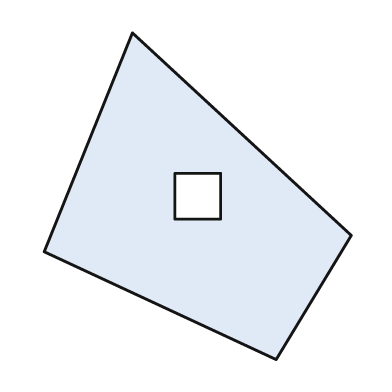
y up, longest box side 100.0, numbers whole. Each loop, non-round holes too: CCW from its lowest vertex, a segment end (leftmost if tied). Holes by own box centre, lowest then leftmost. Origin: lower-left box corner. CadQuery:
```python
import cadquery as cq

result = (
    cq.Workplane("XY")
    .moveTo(71.0, 0.0)
    .lineTo(94.0, 38.0)
    .lineTo(27.0, 100.0)
    .lineTo(0.0, 33.0)
    .close()
    .moveTo(40.0, 43.0)
    .lineTo(54.0, 43.0)
    .lineTo(54.0, 57.0)
    .lineTo(40.0, 57.0)
    .close()
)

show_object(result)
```